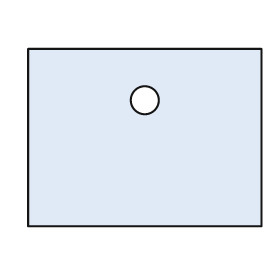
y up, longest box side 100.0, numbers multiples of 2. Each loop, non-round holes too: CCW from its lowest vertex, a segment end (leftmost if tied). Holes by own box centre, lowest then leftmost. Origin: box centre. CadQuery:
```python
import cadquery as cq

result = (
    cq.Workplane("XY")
    .moveTo(-50.0, -38.0)
    .lineTo(50.0, -38.0)
    .lineTo(50.0, 38.0)
    .lineTo(-50.0, 38.0)
    .close()
    .moveTo(0.0, 16.0)
    .circle(6.0)
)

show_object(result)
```